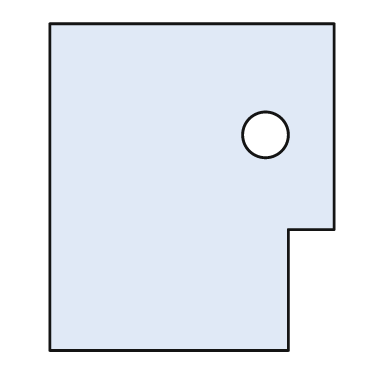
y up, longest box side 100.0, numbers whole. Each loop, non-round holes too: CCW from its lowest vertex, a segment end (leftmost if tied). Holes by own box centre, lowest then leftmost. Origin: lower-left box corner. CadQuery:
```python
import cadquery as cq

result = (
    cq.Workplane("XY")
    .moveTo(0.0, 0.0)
    .lineTo(73.0, 0.0)
    .lineTo(73.0, 37.0)
    .lineTo(87.0, 37.0)
    .lineTo(87.0, 100.0)
    .lineTo(0.0, 100.0)
    .close()
    .moveTo(66.0, 66.0)
    .circle(7.0)
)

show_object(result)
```